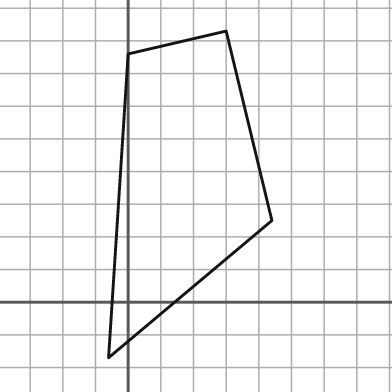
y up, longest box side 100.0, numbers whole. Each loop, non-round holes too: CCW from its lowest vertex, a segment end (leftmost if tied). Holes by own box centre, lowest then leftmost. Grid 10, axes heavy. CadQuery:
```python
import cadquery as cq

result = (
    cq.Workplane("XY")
    .moveTo(-6.0, -17.0)
    .lineTo(44.0, 25.0)
    .lineTo(30.0, 83.0)
    .lineTo(0.0, 76.0)
    .close()
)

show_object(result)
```